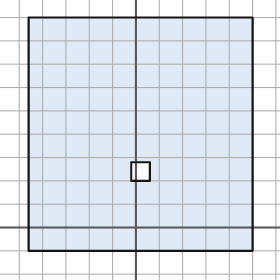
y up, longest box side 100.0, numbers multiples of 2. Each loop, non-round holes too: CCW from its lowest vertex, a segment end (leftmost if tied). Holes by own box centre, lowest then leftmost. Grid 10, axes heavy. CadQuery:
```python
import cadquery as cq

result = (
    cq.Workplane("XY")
    .moveTo(-46.0, -10.0)
    .lineTo(50.0, -10.0)
    .lineTo(50.0, 90.0)
    .lineTo(-46.0, 90.0)
    .close()
    .moveTo(-2.0, 20.0)
    .lineTo(6.0, 20.0)
    .lineTo(6.0, 28.0)
    .lineTo(-2.0, 28.0)
    .close()
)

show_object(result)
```